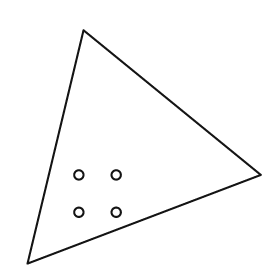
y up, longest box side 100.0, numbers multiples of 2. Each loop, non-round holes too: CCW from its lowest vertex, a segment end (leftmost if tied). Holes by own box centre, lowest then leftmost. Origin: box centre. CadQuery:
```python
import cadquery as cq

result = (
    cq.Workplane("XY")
    .moveTo(-50.0, -50.0)
    .lineTo(50.0, -12.0)
    .lineTo(-26.0, 50.0)
    .close()
    .moveTo(-28.0, -28.0)
    .circle(2.0)
    .moveTo(-12.0, -28.0)
    .circle(2.0)
    .moveTo(-28.0, -12.0)
    .circle(2.0)
    .moveTo(-12.0, -12.0)
    .circle(2.0)
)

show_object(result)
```